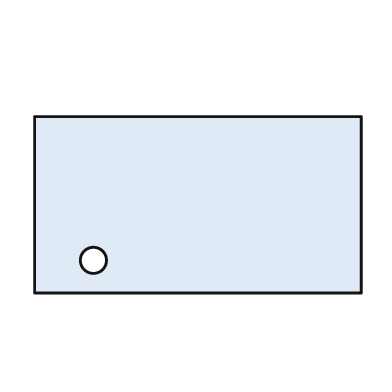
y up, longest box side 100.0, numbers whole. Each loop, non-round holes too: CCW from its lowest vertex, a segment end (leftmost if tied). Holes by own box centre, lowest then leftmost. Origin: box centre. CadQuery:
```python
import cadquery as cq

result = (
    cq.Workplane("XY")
    .moveTo(-50.0, -27.0)
    .lineTo(50.0, -27.0)
    .lineTo(50.0, 27.0)
    .lineTo(-50.0, 27.0)
    .close()
    .moveTo(-32.0, -17.0)
    .circle(4.0)
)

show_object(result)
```